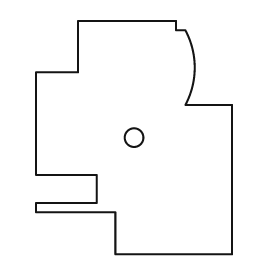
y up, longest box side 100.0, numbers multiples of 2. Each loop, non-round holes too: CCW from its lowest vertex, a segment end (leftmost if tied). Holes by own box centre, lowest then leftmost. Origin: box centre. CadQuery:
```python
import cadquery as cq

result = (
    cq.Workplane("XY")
    .moveTo(-8.0, -50.0)
    .lineTo(42.0, -50.0)
    .lineTo(42.0, 14.0)
    .lineTo(22.0, 14.0)
    .threePointArc((26.0, 30.0), (22.0, 46.0))
    .lineTo(18.0, 46.0)
    .lineTo(18.0, 50.0)
    .lineTo(-24.0, 50.0)
    .lineTo(-24.0, 28.0)
    .lineTo(-42.0, 28.0)
    .lineTo(-42.0, -16.0)
    .lineTo(-16.0, -16.0)
    .lineTo(-16.0, -28.0)
    .lineTo(-42.0, -28.0)
    .lineTo(-42.0, -32.0)
    .lineTo(-8.0, -32.0)
    .close()
    .moveTo(0.0, 0.0)
    .circle(4.0)
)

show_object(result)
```